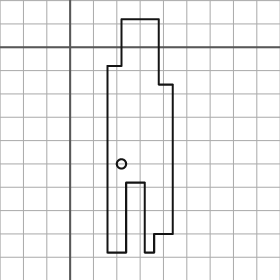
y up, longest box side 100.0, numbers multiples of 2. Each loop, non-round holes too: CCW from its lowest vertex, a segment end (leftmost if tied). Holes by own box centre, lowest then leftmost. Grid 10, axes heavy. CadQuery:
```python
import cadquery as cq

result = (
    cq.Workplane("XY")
    .moveTo(16.0, -88.0)
    .lineTo(24.0, -88.0)
    .lineTo(24.0, -58.0)
    .lineTo(32.0, -58.0)
    .lineTo(32.0, -88.0)
    .lineTo(36.0, -88.0)
    .lineTo(36.0, -80.0)
    .lineTo(44.0, -80.0)
    .lineTo(44.0, -16.0)
    .lineTo(38.0, -16.0)
    .lineTo(38.0, 12.0)
    .lineTo(22.0, 12.0)
    .lineTo(22.0, -8.0)
    .lineTo(16.0, -8.0)
    .close()
    .moveTo(22.0, -50.0)
    .circle(2.0)
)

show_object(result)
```